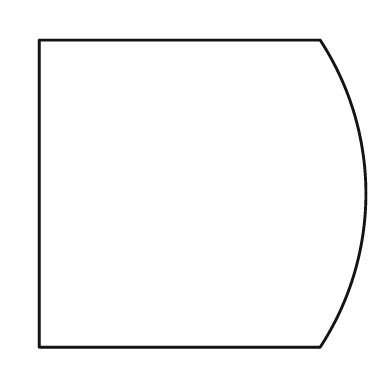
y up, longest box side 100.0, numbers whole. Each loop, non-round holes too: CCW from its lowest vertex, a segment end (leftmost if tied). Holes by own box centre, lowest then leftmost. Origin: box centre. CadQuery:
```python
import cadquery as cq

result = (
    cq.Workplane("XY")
    .moveTo(-50.0, -47.0)
    .lineTo(36.0, -47.0)
    .threePointArc((50.0, 0.0), (36.0, 47.0))
    .lineTo(-50.0, 47.0)
    .close()
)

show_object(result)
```